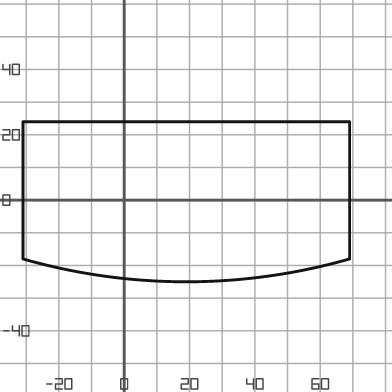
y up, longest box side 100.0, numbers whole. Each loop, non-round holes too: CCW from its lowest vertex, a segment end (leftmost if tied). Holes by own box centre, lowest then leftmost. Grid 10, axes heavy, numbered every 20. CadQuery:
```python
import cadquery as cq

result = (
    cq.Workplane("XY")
    .moveTo(-31.0, -18.0)
    .threePointArc((19.0, -25.0), (69.0, -18.0))
    .lineTo(69.0, 24.0)
    .lineTo(-31.0, 24.0)
    .close()
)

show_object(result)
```